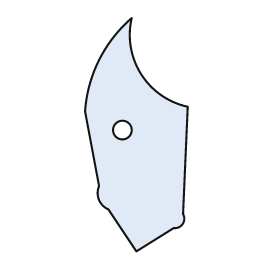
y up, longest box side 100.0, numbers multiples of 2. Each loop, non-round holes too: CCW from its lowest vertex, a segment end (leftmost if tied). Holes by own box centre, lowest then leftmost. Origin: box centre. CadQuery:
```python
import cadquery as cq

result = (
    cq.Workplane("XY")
    .moveTo(0.0, -50.0)
    .lineTo(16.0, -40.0)
    .threePointArc((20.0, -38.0), (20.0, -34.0))
    .lineTo(22.0, 12.0)
    .threePointArc((2.0, 26.0), (-2.0, 50.0))
    .threePointArc((-16.0, 32.0), (-22.0, 10.0))
    .lineTo(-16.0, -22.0)
    .threePointArc((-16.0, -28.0), (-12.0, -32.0))
    .close()
    .moveTo(-6.0, 2.0)
    .circle(4.0)
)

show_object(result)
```